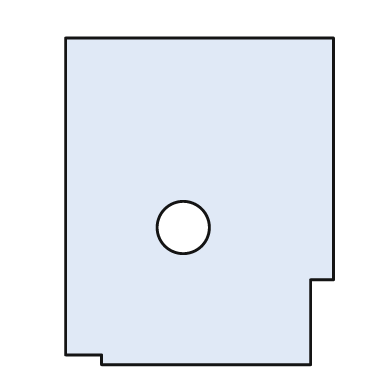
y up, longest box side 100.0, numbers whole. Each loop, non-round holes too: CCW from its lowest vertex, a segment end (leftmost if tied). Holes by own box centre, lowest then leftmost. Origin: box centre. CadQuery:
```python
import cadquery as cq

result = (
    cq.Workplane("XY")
    .moveTo(-30.0, -50.0)
    .lineTo(34.0, -50.0)
    .lineTo(34.0, -24.0)
    .lineTo(41.0, -24.0)
    .lineTo(41.0, 50.0)
    .lineTo(-41.0, 50.0)
    .lineTo(-41.0, -47.0)
    .lineTo(-30.0, -47.0)
    .close()
    .moveTo(-5.0, -8.0)
    .circle(8.0)
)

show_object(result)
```